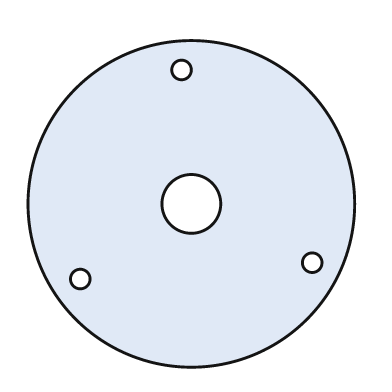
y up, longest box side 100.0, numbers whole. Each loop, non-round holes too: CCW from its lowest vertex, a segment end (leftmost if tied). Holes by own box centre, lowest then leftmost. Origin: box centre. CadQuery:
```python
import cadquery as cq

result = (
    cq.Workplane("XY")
    .moveTo(0.0, 0.0)
    .circle(50.0)
    .moveTo(-34.0, -23.0)
    .circle(3.0)
    .moveTo(37.0, -18.0)
    .circle(3.0)
    .moveTo(0.0, 0.0)
    .circle(9.0)
    .moveTo(-3.0, 41.0)
    .circle(3.0)
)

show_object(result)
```